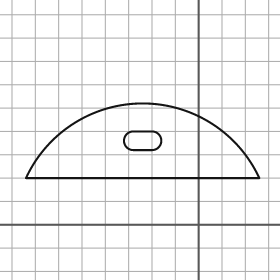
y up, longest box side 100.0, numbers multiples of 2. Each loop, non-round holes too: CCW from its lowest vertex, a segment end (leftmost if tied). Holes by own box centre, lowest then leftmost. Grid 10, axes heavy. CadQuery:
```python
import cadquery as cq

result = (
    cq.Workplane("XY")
    .moveTo(-74.0, 20.0)
    .lineTo(26.0, 20.0)
    .threePointArc((-24.0, 52.0), (-74.0, 20.0))
    .close()
    .moveTo(-28.0, 32.0)
    .lineTo(-20.0, 32.0)
    .threePointArc((-16.0, 36.0), (-20.0, 40.0))
    .lineTo(-28.0, 40.0)
    .threePointArc((-32.0, 36.0), (-28.0, 32.0))
    .close()
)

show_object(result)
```